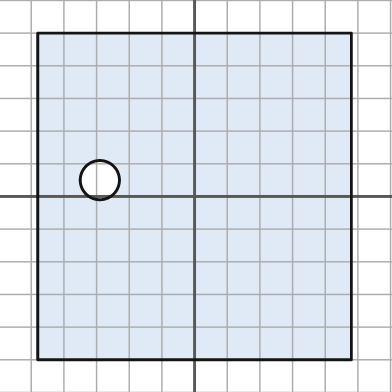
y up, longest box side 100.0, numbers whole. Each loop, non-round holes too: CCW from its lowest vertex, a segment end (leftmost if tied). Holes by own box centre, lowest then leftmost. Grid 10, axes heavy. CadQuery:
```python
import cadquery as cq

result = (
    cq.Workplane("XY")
    .moveTo(-48.0, -50.0)
    .lineTo(48.0, -50.0)
    .lineTo(48.0, 50.0)
    .lineTo(-48.0, 50.0)
    .close()
    .moveTo(-29.0, 5.0)
    .circle(6.0)
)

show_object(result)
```